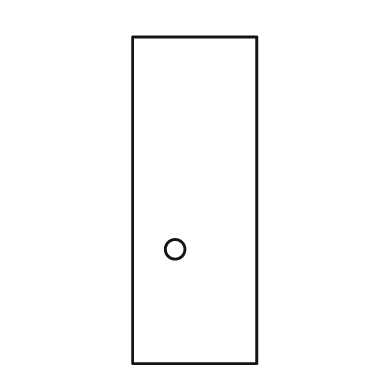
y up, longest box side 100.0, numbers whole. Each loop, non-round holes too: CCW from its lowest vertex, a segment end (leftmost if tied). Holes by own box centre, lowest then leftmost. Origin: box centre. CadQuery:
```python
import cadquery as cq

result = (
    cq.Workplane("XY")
    .moveTo(-19.0, -50.0)
    .lineTo(19.0, -50.0)
    .lineTo(19.0, 50.0)
    .lineTo(-19.0, 50.0)
    .close()
    .moveTo(-6.0, -15.0)
    .circle(3.0)
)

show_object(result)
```